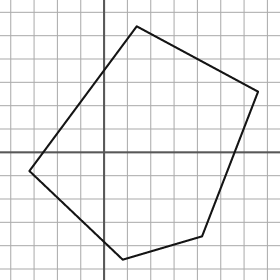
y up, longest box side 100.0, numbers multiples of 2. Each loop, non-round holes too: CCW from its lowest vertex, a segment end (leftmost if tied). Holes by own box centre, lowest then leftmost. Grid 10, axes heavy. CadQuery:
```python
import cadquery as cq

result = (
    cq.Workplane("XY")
    .moveTo(8.0, -46.0)
    .lineTo(42.0, -36.0)
    .lineTo(66.0, 26.0)
    .lineTo(14.0, 54.0)
    .lineTo(-32.0, -8.0)
    .close()
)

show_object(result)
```